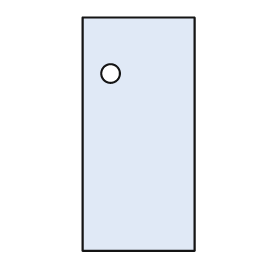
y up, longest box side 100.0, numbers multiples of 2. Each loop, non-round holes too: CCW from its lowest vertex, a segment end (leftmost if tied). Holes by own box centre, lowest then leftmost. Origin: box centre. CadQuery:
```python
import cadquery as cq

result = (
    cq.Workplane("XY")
    .moveTo(-24.0, -50.0)
    .lineTo(24.0, -50.0)
    .lineTo(24.0, 50.0)
    .lineTo(-24.0, 50.0)
    .close()
    .moveTo(-12.0, 26.0)
    .circle(4.0)
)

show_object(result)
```